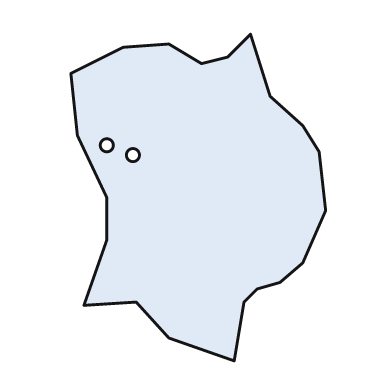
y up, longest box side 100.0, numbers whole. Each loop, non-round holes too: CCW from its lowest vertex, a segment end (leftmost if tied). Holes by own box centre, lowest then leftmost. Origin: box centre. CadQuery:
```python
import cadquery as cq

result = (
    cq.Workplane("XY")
    .moveTo(11.0, -50.0)
    .lineTo(14.0, -32.0)
    .lineTo(18.0, -28.0)
    .lineTo(25.0, -26.0)
    .lineTo(32.0, -20.0)
    .lineTo(39.0, -4.0)
    .lineTo(37.0, 14.0)
    .lineTo(32.0, 22.0)
    .lineTo(22.0, 31.0)
    .lineTo(16.0, 50.0)
    .lineTo(9.0, 43.0)
    .lineTo(1.0, 41.0)
    .lineTo(-9.0, 47.0)
    .lineTo(-23.0, 46.0)
    .lineTo(-39.0, 38.0)
    .lineTo(-37.0, 19.0)
    .lineTo(-28.0, 0.0)
    .lineTo(-28.0, -13.0)
    .lineTo(-35.0, -33.0)
    .lineTo(-19.0, -32.0)
    .lineTo(-9.0, -43.0)
    .close()
    .moveTo(-20.0, 13.0)
    .circle(2.0)
    .moveTo(-28.0, 16.0)
    .circle(2.0)
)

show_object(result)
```